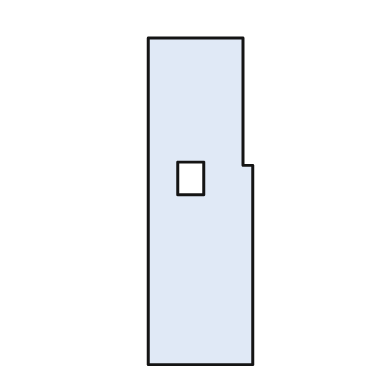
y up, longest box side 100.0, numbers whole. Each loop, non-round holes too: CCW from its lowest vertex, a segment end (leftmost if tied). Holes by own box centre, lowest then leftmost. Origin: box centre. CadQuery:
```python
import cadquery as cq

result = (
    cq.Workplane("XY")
    .moveTo(-16.0, -50.0)
    .lineTo(16.0, -50.0)
    .lineTo(16.0, 11.0)
    .lineTo(13.0, 11.0)
    .lineTo(13.0, 50.0)
    .lineTo(-16.0, 50.0)
    .close()
    .moveTo(-7.0, 2.0)
    .lineTo(1.0, 2.0)
    .lineTo(1.0, 12.0)
    .lineTo(-7.0, 12.0)
    .close()
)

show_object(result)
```